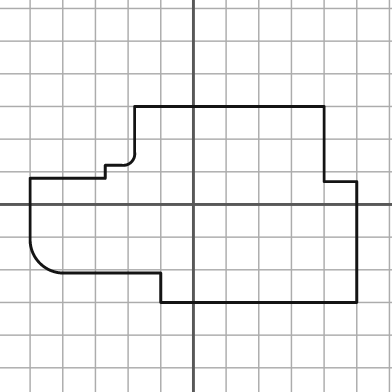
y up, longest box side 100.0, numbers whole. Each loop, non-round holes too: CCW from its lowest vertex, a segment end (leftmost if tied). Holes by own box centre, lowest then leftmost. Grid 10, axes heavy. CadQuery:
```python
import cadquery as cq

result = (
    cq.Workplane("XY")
    .moveTo(-10.0, -30.0)
    .lineTo(50.0, -30.0)
    .lineTo(50.0, 7.0)
    .lineTo(40.0, 7.0)
    .lineTo(40.0, 30.0)
    .lineTo(-18.0, 30.0)
    .lineTo(-18.0, 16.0)
    .threePointArc((-19.0, 13.0), (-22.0, 12.0))
    .lineTo(-27.0, 12.0)
    .lineTo(-27.0, 8.0)
    .lineTo(-50.0, 8.0)
    .lineTo(-50.0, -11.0)
    .threePointArc((-47.0, -18.0), (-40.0, -21.0))
    .lineTo(-10.0, -21.0)
    .close()
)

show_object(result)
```